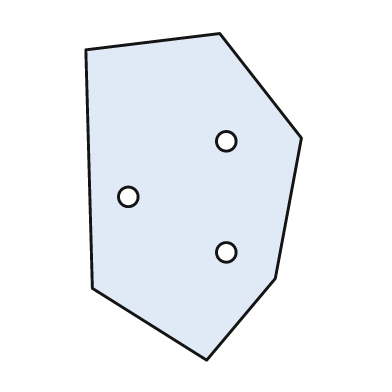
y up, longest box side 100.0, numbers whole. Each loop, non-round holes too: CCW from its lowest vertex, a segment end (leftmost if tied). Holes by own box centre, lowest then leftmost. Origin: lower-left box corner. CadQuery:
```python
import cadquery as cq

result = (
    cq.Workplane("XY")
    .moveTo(37.0, 0.0)
    .lineTo(58.0, 25.0)
    .lineTo(66.0, 68.0)
    .lineTo(41.0, 100.0)
    .lineTo(0.0, 95.0)
    .lineTo(2.0, 22.0)
    .close()
    .moveTo(43.0, 33.0)
    .circle(3.0)
    .moveTo(13.0, 50.0)
    .circle(3.0)
    .moveTo(43.0, 67.0)
    .circle(3.0)
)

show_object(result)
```